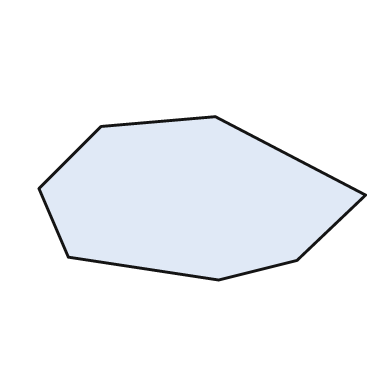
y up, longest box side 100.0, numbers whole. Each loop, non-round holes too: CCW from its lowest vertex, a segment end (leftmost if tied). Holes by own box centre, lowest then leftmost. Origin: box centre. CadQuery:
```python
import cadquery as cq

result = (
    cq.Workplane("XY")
    .moveTo(5.0, -25.0)
    .lineTo(29.0, -19.0)
    .lineTo(50.0, 1.0)
    .lineTo(4.0, 25.0)
    .lineTo(-31.0, 22.0)
    .lineTo(-50.0, 3.0)
    .lineTo(-41.0, -18.0)
    .close()
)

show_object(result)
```